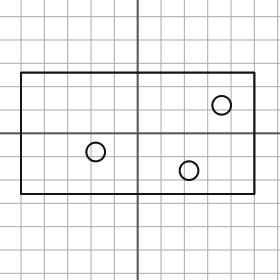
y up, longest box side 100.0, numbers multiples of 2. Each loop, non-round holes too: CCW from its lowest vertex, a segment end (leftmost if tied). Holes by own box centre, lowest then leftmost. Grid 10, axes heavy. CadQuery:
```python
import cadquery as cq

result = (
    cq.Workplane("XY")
    .moveTo(-50.0, -26.0)
    .lineTo(50.0, -26.0)
    .lineTo(50.0, 26.0)
    .lineTo(-50.0, 26.0)
    .close()
    .moveTo(22.0, -16.0)
    .circle(4.0)
    .moveTo(-18.0, -8.0)
    .circle(4.0)
    .moveTo(36.0, 12.0)
    .circle(4.0)
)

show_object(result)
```